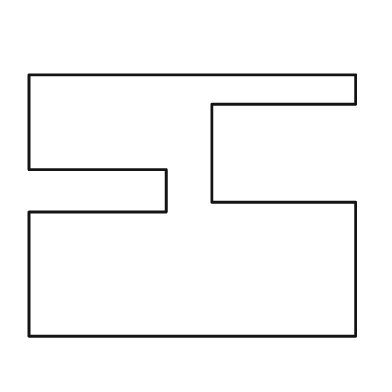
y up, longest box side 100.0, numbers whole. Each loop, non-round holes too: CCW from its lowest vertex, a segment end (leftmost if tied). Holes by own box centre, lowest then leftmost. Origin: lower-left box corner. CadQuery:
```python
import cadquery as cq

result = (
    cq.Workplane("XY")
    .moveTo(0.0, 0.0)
    .lineTo(100.0, 0.0)
    .lineTo(100.0, 41.0)
    .lineTo(56.0, 41.0)
    .lineTo(56.0, 71.0)
    .lineTo(100.0, 71.0)
    .lineTo(100.0, 80.0)
    .lineTo(0.0, 80.0)
    .lineTo(0.0, 51.0)
    .lineTo(42.0, 51.0)
    .lineTo(42.0, 38.0)
    .lineTo(0.0, 38.0)
    .close()
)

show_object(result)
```